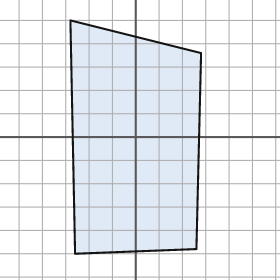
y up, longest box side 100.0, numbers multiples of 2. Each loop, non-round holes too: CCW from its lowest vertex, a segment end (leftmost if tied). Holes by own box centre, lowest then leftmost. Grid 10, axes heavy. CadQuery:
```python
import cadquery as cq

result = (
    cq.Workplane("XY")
    .moveTo(-26.0, -50.0)
    .lineTo(26.0, -48.0)
    .lineTo(28.0, 36.0)
    .lineTo(-28.0, 50.0)
    .close()
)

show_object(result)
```